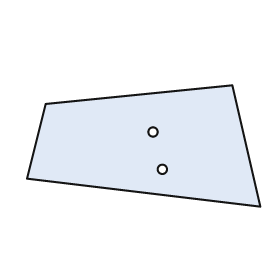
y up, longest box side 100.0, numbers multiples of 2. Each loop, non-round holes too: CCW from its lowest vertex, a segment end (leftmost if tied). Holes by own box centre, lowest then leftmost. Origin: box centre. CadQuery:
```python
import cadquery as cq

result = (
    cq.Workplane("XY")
    .moveTo(50.0, -26.0)
    .lineTo(38.0, 26.0)
    .lineTo(-42.0, 18.0)
    .lineTo(-50.0, -14.0)
    .close()
    .moveTo(8.0, -10.0)
    .circle(2.0)
    .moveTo(4.0, 6.0)
    .circle(2.0)
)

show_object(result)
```